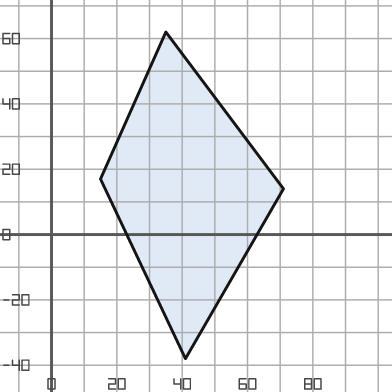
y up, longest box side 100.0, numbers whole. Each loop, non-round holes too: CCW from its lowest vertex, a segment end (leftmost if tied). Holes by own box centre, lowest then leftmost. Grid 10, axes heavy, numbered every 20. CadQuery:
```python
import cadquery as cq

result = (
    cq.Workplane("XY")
    .moveTo(41.0, -38.0)
    .lineTo(71.0, 14.0)
    .lineTo(35.0, 62.0)
    .lineTo(15.0, 17.0)
    .close()
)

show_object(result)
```